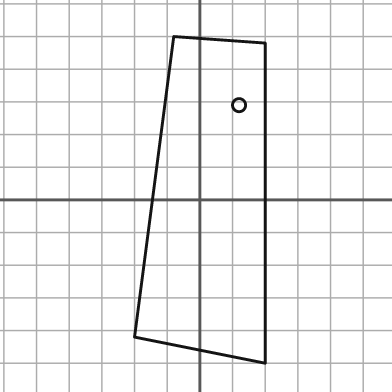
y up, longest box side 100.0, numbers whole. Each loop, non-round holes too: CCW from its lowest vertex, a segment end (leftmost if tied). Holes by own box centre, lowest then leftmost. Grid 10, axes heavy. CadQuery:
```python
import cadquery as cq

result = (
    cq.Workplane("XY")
    .moveTo(20.0, -50.0)
    .lineTo(20.0, 48.0)
    .lineTo(-8.0, 50.0)
    .lineTo(-20.0, -42.0)
    .close()
    .moveTo(12.0, 29.0)
    .circle(2.0)
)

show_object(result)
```